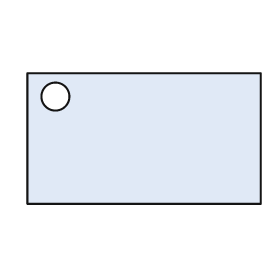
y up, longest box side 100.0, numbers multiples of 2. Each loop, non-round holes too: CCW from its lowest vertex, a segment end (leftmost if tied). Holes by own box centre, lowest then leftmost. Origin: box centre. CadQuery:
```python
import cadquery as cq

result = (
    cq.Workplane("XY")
    .moveTo(-50.0, -28.0)
    .lineTo(50.0, -28.0)
    .lineTo(50.0, 28.0)
    .lineTo(-50.0, 28.0)
    .close()
    .moveTo(-38.0, 18.0)
    .circle(6.0)
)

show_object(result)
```